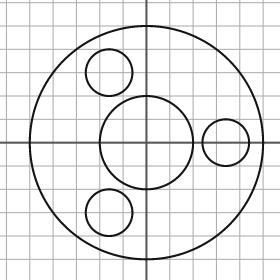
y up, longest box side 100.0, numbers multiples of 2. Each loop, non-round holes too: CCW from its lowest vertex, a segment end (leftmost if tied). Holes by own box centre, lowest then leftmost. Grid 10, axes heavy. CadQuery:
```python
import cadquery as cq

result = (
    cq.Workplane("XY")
    .moveTo(0.0, 0.0)
    .circle(50.0)
    .moveTo(-16.0, -30.0)
    .circle(10.0)
    .moveTo(0.0, 0.0)
    .circle(20.0)
    .moveTo(34.0, 0.0)
    .circle(10.0)
    .moveTo(-16.0, 30.0)
    .circle(10.0)
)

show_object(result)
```